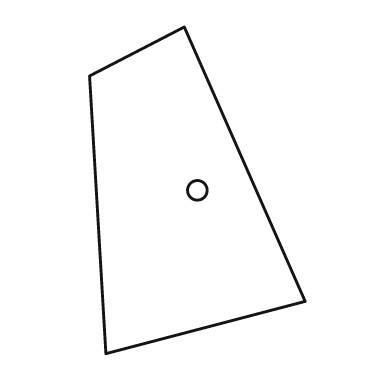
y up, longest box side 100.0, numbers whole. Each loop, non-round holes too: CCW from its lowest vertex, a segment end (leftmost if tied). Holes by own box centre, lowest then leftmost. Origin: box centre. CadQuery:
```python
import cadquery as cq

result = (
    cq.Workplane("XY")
    .moveTo(-28.0, -50.0)
    .lineTo(33.0, -34.0)
    .lineTo(-4.0, 50.0)
    .lineTo(-33.0, 35.0)
    .close()
    .moveTo(0.0, 0.0)
    .circle(3.0)
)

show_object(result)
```